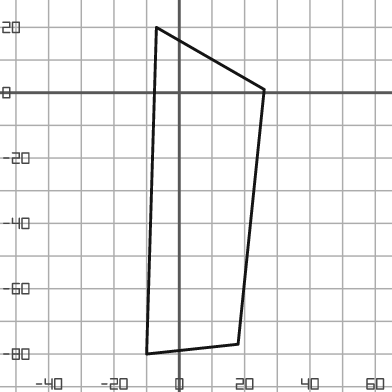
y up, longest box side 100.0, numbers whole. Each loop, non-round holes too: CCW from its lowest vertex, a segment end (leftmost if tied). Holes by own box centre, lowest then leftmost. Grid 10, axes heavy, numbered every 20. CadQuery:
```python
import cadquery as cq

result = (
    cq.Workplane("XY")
    .moveTo(-10.0, -80.0)
    .lineTo(18.0, -77.0)
    .lineTo(26.0, 1.0)
    .lineTo(-7.0, 20.0)
    .close()
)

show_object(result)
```